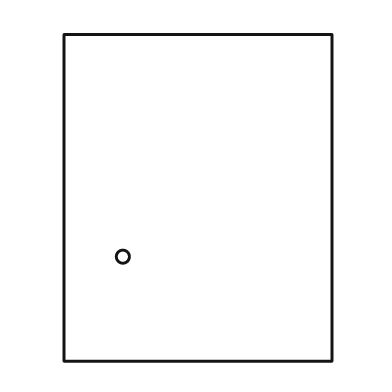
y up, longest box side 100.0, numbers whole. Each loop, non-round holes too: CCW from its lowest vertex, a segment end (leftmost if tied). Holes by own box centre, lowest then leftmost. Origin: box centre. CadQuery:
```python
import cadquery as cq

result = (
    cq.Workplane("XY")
    .moveTo(-41.0, -50.0)
    .lineTo(41.0, -50.0)
    .lineTo(41.0, 50.0)
    .lineTo(-41.0, 50.0)
    .close()
    .moveTo(-23.0, -18.0)
    .circle(2.0)
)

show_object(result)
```